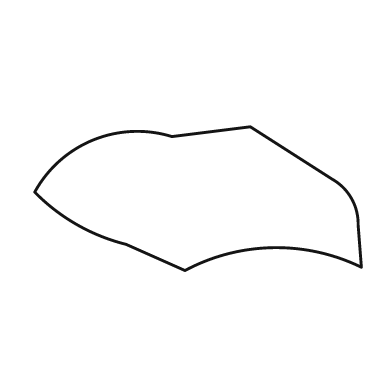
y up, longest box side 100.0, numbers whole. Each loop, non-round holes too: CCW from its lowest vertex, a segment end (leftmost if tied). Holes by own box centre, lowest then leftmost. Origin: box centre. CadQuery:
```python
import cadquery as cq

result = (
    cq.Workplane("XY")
    .moveTo(-4.0, -22.0)
    .threePointArc((23.0, -15.0), (50.0, -21.0))
    .lineTo(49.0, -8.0)
    .threePointArc((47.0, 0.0), (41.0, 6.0))
    .lineTo(16.0, 22.0)
    .lineTo(-8.0, 19.0)
    .threePointArc((-32.0, 18.0), (-50.0, 2.0))
    .threePointArc((-37.0, -8.0), (-22.0, -14.0))
    .close()
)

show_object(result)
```